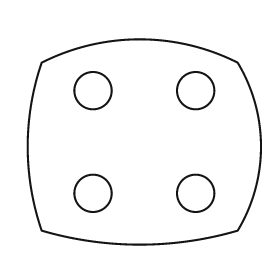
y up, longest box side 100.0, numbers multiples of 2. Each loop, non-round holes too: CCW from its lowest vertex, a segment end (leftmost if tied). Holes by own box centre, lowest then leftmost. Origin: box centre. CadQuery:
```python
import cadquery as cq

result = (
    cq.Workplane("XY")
    .moveTo(-44.0, -38.0)
    .threePointArc((-2.0, -44.0), (40.0, -38.0))
    .threePointArc((50.0, -2.0), (40.0, 34.0))
    .threePointArc((-2.0, 44.0), (-44.0, 34.0))
    .threePointArc((-50.0, -2.0), (-44.0, -38.0))
    .close()
    .moveTo(-22.0, -22.0)
    .circle(8.0)
    .moveTo(22.0, -22.0)
    .circle(8.0)
    .moveTo(-22.0, 22.0)
    .circle(8.0)
    .moveTo(22.0, 22.0)
    .circle(8.0)
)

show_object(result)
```